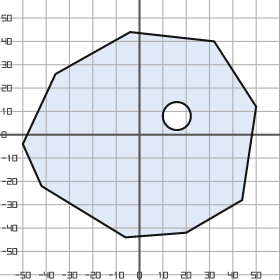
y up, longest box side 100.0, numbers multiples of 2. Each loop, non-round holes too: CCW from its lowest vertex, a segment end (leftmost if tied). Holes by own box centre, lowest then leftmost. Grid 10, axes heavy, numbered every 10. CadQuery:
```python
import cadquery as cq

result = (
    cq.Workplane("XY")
    .moveTo(-6.0, -44.0)
    .lineTo(20.0, -42.0)
    .lineTo(44.0, -28.0)
    .lineTo(50.0, 12.0)
    .lineTo(32.0, 40.0)
    .lineTo(-4.0, 44.0)
    .lineTo(-36.0, 26.0)
    .lineTo(-50.0, -4.0)
    .lineTo(-42.0, -22.0)
    .close()
    .moveTo(16.0, 8.0)
    .circle(6.0)
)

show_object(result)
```